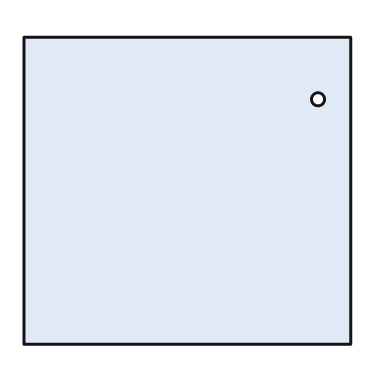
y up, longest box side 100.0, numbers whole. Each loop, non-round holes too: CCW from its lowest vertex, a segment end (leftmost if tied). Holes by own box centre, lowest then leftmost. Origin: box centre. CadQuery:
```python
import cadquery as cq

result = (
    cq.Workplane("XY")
    .moveTo(-50.0, -47.0)
    .lineTo(50.0, -47.0)
    .lineTo(50.0, 47.0)
    .lineTo(-50.0, 47.0)
    .close()
    .moveTo(40.0, 28.0)
    .circle(2.0)
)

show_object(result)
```